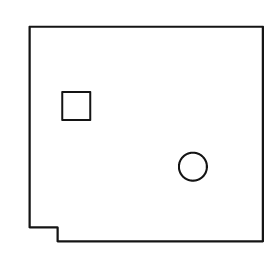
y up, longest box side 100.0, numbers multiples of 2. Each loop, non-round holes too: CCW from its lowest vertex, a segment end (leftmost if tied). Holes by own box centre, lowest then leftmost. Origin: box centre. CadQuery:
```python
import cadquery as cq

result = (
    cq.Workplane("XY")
    .moveTo(-38.0, -46.0)
    .lineTo(50.0, -46.0)
    .lineTo(50.0, 46.0)
    .lineTo(-50.0, 46.0)
    .lineTo(-50.0, -40.0)
    .lineTo(-38.0, -40.0)
    .close()
    .moveTo(20.0, -14.0)
    .circle(6.0)
    .moveTo(-36.0, 6.0)
    .lineTo(-24.0, 6.0)
    .lineTo(-24.0, 18.0)
    .lineTo(-36.0, 18.0)
    .close()
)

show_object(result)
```